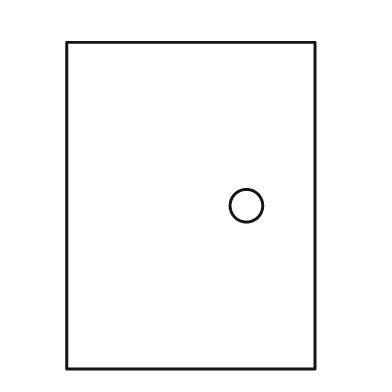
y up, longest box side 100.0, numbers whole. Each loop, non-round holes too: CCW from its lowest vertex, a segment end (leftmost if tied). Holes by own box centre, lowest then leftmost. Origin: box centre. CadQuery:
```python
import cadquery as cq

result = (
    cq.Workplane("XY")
    .moveTo(-38.0, -50.0)
    .lineTo(38.0, -50.0)
    .lineTo(38.0, 50.0)
    .lineTo(-38.0, 50.0)
    .close()
    .moveTo(17.0, 0.0)
    .circle(5.0)
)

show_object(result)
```